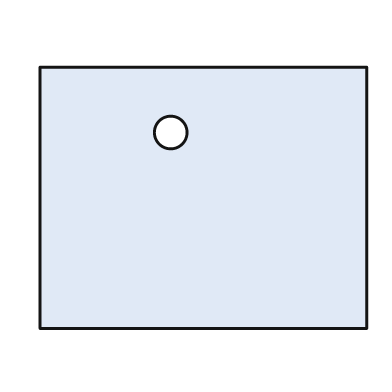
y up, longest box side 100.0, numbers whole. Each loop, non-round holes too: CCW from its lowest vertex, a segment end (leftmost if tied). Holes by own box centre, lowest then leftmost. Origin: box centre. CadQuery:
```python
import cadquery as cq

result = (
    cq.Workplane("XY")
    .moveTo(-50.0, -40.0)
    .lineTo(50.0, -40.0)
    .lineTo(50.0, 40.0)
    .lineTo(-50.0, 40.0)
    .close()
    .moveTo(-10.0, 20.0)
    .circle(5.0)
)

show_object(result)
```